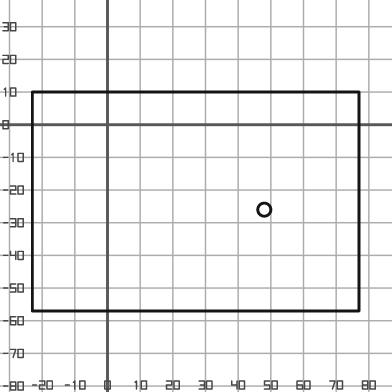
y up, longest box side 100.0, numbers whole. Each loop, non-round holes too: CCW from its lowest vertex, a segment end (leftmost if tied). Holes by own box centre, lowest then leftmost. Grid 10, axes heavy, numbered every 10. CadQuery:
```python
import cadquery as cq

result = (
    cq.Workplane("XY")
    .moveTo(-23.0, -57.0)
    .lineTo(77.0, -57.0)
    .lineTo(77.0, 10.0)
    .lineTo(-23.0, 10.0)
    .close()
    .moveTo(48.0, -26.0)
    .circle(2.0)
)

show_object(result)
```